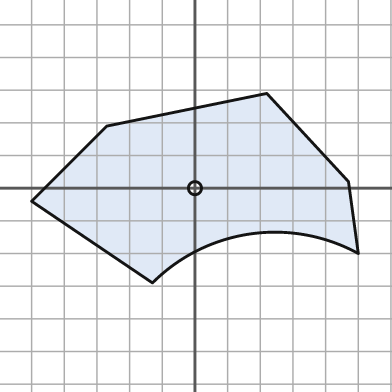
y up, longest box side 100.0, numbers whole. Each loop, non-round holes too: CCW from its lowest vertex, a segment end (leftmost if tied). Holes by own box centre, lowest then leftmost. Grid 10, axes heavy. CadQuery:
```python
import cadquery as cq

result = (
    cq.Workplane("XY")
    .moveTo(-13.0, -29.0)
    .threePointArc((17.0, -14.0), (50.0, -20.0))
    .lineTo(47.0, 2.0)
    .lineTo(22.0, 29.0)
    .lineTo(-27.0, 19.0)
    .lineTo(-50.0, -4.0)
    .close()
    .moveTo(0.0, 0.0)
    .circle(2.0)
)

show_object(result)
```